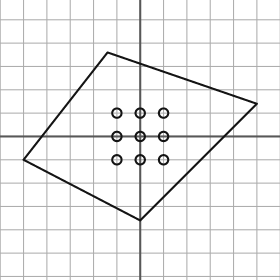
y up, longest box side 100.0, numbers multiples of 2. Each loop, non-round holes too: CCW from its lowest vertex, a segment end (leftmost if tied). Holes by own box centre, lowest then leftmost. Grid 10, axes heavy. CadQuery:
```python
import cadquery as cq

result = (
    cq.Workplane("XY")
    .moveTo(0.0, -36.0)
    .lineTo(50.0, 14.0)
    .lineTo(-14.0, 36.0)
    .lineTo(-50.0, -10.0)
    .close()
    .moveTo(-10.0, -10.0)
    .circle(2.0)
    .moveTo(0.0, -10.0)
    .circle(2.0)
    .moveTo(10.0, -10.0)
    .circle(2.0)
    .moveTo(-10.0, 0.0)
    .circle(2.0)
    .moveTo(0.0, 0.0)
    .circle(2.0)
    .moveTo(10.0, 0.0)
    .circle(2.0)
    .moveTo(-10.0, 10.0)
    .circle(2.0)
    .moveTo(0.0, 10.0)
    .circle(2.0)
    .moveTo(10.0, 10.0)
    .circle(2.0)
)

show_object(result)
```